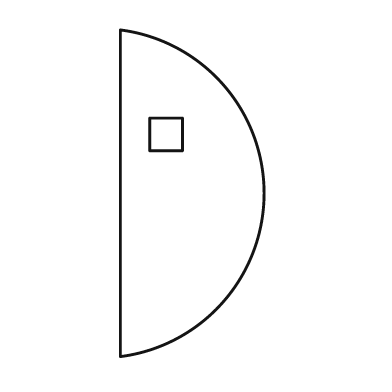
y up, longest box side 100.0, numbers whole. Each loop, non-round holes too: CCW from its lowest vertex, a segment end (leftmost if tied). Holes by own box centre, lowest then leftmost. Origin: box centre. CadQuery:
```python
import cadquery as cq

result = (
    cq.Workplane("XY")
    .moveTo(-22.0, -50.0)
    .threePointArc((22.0, 0.0), (-22.0, 50.0))
    .close()
    .moveTo(-13.0, 13.0)
    .lineTo(-3.0, 13.0)
    .lineTo(-3.0, 23.0)
    .lineTo(-13.0, 23.0)
    .close()
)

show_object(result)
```